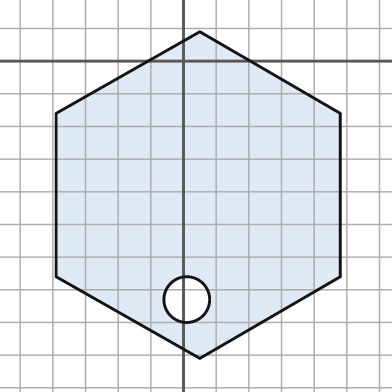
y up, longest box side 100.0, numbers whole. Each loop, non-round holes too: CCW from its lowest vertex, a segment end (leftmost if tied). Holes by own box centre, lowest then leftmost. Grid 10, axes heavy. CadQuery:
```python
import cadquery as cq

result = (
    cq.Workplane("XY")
    .moveTo(5.0, -91.0)
    .lineTo(48.0, -66.0)
    .lineTo(48.0, -16.0)
    .lineTo(5.0, 9.0)
    .lineTo(-39.0, -16.0)
    .lineTo(-39.0, -66.0)
    .close()
    .moveTo(1.0, -73.0)
    .circle(7.0)
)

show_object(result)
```